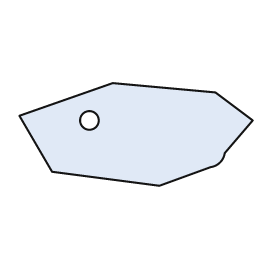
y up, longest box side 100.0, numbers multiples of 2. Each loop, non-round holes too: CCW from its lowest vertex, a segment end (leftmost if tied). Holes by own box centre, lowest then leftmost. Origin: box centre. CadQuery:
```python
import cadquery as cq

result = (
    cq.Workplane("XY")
    .moveTo(10.0, -22.0)
    .lineTo(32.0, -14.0)
    .threePointArc((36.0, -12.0), (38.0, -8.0))
    .lineTo(50.0, 6.0)
    .lineTo(34.0, 18.0)
    .lineTo(-10.0, 22.0)
    .lineTo(-50.0, 8.0)
    .lineTo(-36.0, -16.0)
    .close()
    .moveTo(-20.0, 6.0)
    .circle(4.0)
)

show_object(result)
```